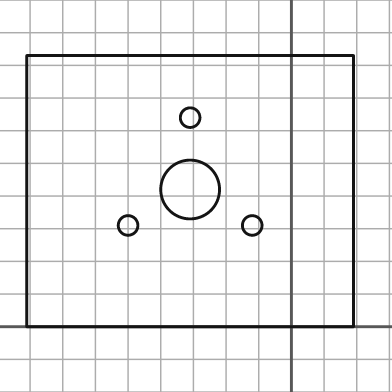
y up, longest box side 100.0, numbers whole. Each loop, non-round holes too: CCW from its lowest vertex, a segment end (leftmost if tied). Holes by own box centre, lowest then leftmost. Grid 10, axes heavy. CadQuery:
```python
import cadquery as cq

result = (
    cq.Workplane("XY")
    .moveTo(-81.0, 0.0)
    .lineTo(19.0, 0.0)
    .lineTo(19.0, 83.0)
    .lineTo(-81.0, 83.0)
    .close()
    .moveTo(-50.0, 31.0)
    .circle(3.0)
    .moveTo(-12.0, 31.0)
    .circle(3.0)
    .moveTo(-31.0, 42.0)
    .circle(9.0)
    .moveTo(-31.0, 64.0)
    .circle(3.0)
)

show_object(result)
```